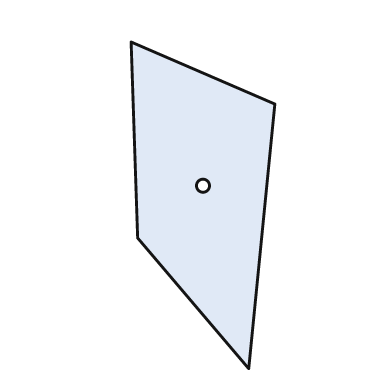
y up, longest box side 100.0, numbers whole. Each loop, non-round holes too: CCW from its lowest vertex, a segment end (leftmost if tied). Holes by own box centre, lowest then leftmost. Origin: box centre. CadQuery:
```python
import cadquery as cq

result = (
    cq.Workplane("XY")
    .moveTo(14.0, -50.0)
    .lineTo(22.0, 31.0)
    .lineTo(-22.0, 50.0)
    .lineTo(-20.0, -10.0)
    .close()
    .moveTo(0.0, 6.0)
    .circle(2.0)
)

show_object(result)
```